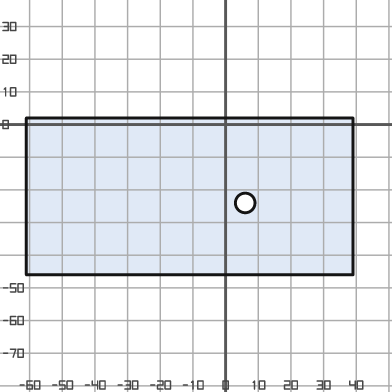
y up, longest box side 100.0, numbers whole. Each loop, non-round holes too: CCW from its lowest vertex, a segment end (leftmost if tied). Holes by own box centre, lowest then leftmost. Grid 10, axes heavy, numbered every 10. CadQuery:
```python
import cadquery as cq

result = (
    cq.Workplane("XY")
    .moveTo(-61.0, -46.0)
    .lineTo(39.0, -46.0)
    .lineTo(39.0, 2.0)
    .lineTo(-61.0, 2.0)
    .close()
    .moveTo(6.0, -24.0)
    .circle(3.0)
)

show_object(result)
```